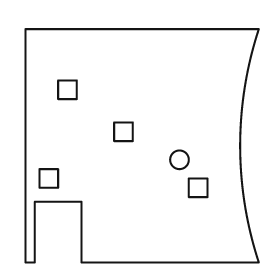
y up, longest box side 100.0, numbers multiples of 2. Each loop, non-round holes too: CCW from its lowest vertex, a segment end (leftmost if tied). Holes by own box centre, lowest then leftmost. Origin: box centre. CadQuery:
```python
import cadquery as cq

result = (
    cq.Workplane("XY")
    .moveTo(-50.0, -50.0)
    .lineTo(-46.0, -50.0)
    .lineTo(-46.0, -24.0)
    .lineTo(-26.0, -24.0)
    .lineTo(-26.0, -50.0)
    .lineTo(50.0, -50.0)
    .threePointArc((42.0, 0.0), (50.0, 50.0))
    .lineTo(-50.0, 50.0)
    .close()
    .moveTo(20.0, -22.0)
    .lineTo(28.0, -22.0)
    .lineTo(28.0, -14.0)
    .lineTo(20.0, -14.0)
    .close()
    .moveTo(-44.0, -18.0)
    .lineTo(-36.0, -18.0)
    .lineTo(-36.0, -10.0)
    .lineTo(-44.0, -10.0)
    .close()
    .moveTo(16.0, -6.0)
    .circle(4.0)
    .moveTo(-12.0, 2.0)
    .lineTo(-4.0, 2.0)
    .lineTo(-4.0, 10.0)
    .lineTo(-12.0, 10.0)
    .close()
    .moveTo(-36.0, 20.0)
    .lineTo(-28.0, 20.0)
    .lineTo(-28.0, 28.0)
    .lineTo(-36.0, 28.0)
    .close()
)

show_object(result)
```